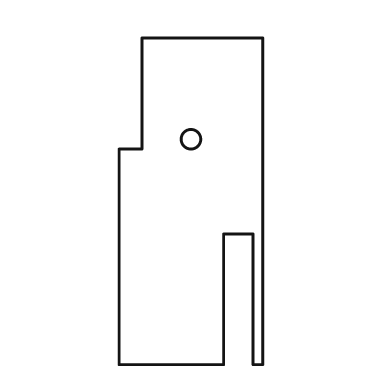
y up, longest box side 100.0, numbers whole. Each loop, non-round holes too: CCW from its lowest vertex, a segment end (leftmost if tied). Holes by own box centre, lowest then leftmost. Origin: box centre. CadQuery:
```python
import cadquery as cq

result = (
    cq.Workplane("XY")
    .moveTo(-22.0, -50.0)
    .lineTo(10.0, -50.0)
    .lineTo(10.0, -10.0)
    .lineTo(19.0, -10.0)
    .lineTo(19.0, -50.0)
    .lineTo(22.0, -50.0)
    .lineTo(22.0, 50.0)
    .lineTo(-15.0, 50.0)
    .lineTo(-15.0, 16.0)
    .lineTo(-22.0, 16.0)
    .close()
    .moveTo(0.0, 19.0)
    .circle(3.0)
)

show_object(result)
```